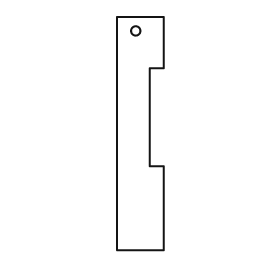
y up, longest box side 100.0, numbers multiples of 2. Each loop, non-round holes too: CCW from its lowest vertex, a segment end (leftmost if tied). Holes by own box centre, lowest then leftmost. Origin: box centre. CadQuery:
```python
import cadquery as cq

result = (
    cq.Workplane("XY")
    .moveTo(-10.0, -50.0)
    .lineTo(10.0, -50.0)
    .lineTo(10.0, -14.0)
    .lineTo(4.0, -14.0)
    .lineTo(4.0, 28.0)
    .lineTo(10.0, 28.0)
    .lineTo(10.0, 50.0)
    .lineTo(-10.0, 50.0)
    .close()
    .moveTo(-2.0, 44.0)
    .circle(2.0)
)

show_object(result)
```